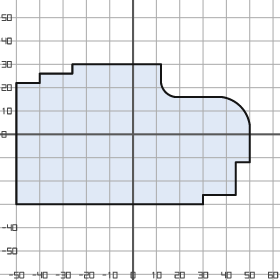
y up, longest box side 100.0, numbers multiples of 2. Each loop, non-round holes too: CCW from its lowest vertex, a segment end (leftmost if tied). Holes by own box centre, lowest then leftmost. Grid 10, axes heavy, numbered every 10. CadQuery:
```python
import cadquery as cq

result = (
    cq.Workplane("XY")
    .moveTo(-50.0, -30.0)
    .lineTo(30.0, -30.0)
    .lineTo(30.0, -26.0)
    .lineTo(44.0, -26.0)
    .lineTo(44.0, -12.0)
    .lineTo(50.0, -12.0)
    .lineTo(50.0, 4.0)
    .threePointArc((46.0, 12.0), (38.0, 16.0))
    .lineTo(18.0, 16.0)
    .threePointArc((14.0, 18.0), (12.0, 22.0))
    .lineTo(12.0, 30.0)
    .lineTo(-26.0, 30.0)
    .lineTo(-26.0, 26.0)
    .lineTo(-40.0, 26.0)
    .lineTo(-40.0, 22.0)
    .lineTo(-50.0, 22.0)
    .close()
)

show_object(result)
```